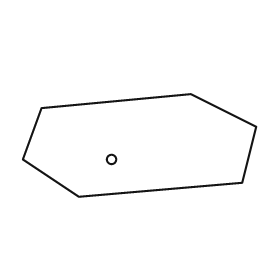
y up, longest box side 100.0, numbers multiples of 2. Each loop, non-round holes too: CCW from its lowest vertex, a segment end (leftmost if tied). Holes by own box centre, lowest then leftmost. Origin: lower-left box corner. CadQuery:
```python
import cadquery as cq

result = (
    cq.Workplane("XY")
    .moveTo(24.0, 0.0)
    .lineTo(94.0, 6.0)
    .lineTo(100.0, 30.0)
    .lineTo(72.0, 44.0)
    .lineTo(8.0, 38.0)
    .lineTo(0.0, 16.0)
    .close()
    .moveTo(38.0, 16.0)
    .circle(2.0)
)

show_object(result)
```